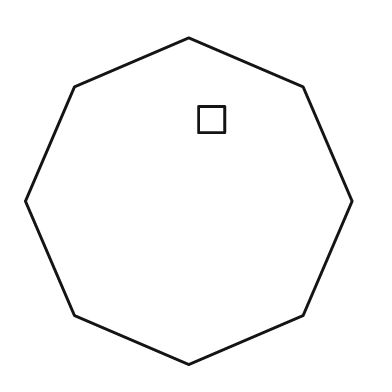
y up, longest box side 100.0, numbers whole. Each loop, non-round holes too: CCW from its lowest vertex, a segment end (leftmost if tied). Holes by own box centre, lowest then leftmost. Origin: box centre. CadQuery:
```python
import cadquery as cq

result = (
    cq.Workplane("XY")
    .moveTo(0.0, -50.0)
    .lineTo(35.0, -35.0)
    .lineTo(50.0, 0.0)
    .lineTo(35.0, 35.0)
    .lineTo(0.0, 50.0)
    .lineTo(-35.0, 35.0)
    .lineTo(-50.0, 0.0)
    .lineTo(-35.0, -35.0)
    .close()
    .moveTo(3.0, 21.0)
    .lineTo(11.0, 21.0)
    .lineTo(11.0, 29.0)
    .lineTo(3.0, 29.0)
    .close()
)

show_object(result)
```